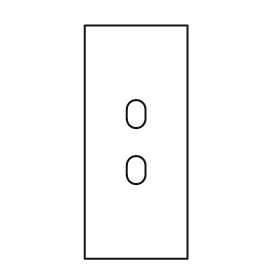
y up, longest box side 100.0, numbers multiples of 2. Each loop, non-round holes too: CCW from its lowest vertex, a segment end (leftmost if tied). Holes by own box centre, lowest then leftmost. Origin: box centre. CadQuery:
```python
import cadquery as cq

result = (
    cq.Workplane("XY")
    .moveTo(-22.0, -50.0)
    .lineTo(22.0, -50.0)
    .lineTo(22.0, 50.0)
    .lineTo(-22.0, 50.0)
    .close()
    .moveTo(-4.0, -14.0)
    .threePointArc((0.0, -18.0), (4.0, -14.0))
    .lineTo(4.0, -10.0)
    .threePointArc((0.0, -6.0), (-4.0, -10.0))
    .close()
    .moveTo(-4.0, 10.0)
    .threePointArc((0.0, 6.0), (4.0, 10.0))
    .lineTo(4.0, 14.0)
    .threePointArc((0.0, 18.0), (-4.0, 14.0))
    .close()
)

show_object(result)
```